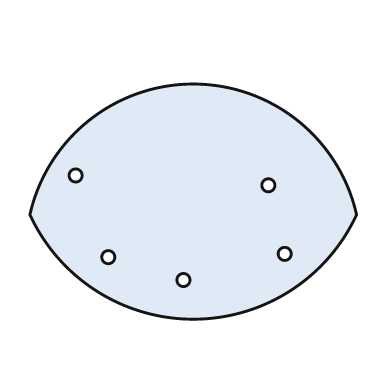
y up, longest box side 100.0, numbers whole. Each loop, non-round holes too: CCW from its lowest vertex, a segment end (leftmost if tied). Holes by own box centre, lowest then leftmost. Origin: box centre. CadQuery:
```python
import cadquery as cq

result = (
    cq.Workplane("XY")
    .moveTo(-50.0, -4.0)
    .threePointArc((0.0, -36.0), (50.0, -4.0))
    .threePointArc((0.0, 36.0), (-50.0, -4.0))
    .close()
    .moveTo(-3.0, -24.0)
    .circle(2.0)
    .moveTo(-26.0, -17.0)
    .circle(2.0)
    .moveTo(28.0, -16.0)
    .circle(2.0)
    .moveTo(23.0, 5.0)
    .circle(2.0)
    .moveTo(-36.0, 8.0)
    .circle(2.0)
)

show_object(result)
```